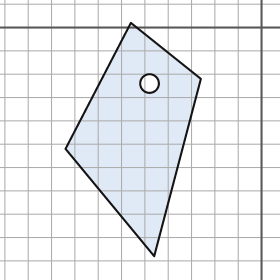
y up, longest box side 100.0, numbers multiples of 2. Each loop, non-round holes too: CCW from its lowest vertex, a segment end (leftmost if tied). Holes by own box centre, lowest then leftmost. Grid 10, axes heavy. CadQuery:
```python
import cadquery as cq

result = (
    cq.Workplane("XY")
    .moveTo(-46.0, -98.0)
    .lineTo(-26.0, -22.0)
    .lineTo(-56.0, 2.0)
    .lineTo(-84.0, -52.0)
    .close()
    .moveTo(-48.0, -24.0)
    .circle(4.0)
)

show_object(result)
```